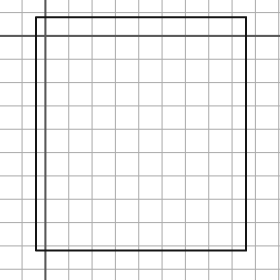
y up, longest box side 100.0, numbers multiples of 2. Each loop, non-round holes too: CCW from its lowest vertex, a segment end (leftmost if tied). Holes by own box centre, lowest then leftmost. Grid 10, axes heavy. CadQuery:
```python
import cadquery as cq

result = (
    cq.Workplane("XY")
    .moveTo(-4.0, -92.0)
    .lineTo(86.0, -92.0)
    .lineTo(86.0, 8.0)
    .lineTo(-4.0, 8.0)
    .close()
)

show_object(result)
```